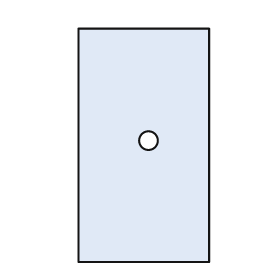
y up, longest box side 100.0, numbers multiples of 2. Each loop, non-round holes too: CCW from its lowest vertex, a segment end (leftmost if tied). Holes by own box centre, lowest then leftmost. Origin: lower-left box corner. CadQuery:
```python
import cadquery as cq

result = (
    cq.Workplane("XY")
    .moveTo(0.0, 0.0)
    .lineTo(56.0, 0.0)
    .lineTo(56.0, 100.0)
    .lineTo(0.0, 100.0)
    .close()
    .moveTo(30.0, 52.0)
    .circle(4.0)
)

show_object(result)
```